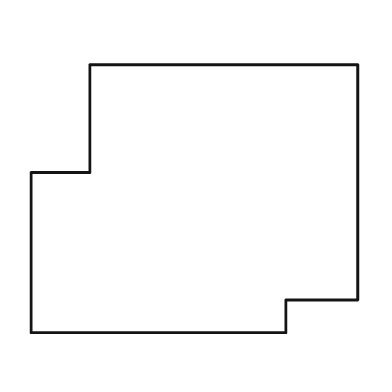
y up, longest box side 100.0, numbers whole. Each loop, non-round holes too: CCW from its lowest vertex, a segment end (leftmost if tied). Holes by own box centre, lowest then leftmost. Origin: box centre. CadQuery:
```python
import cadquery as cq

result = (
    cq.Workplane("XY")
    .moveTo(-50.0, -41.0)
    .lineTo(28.0, -41.0)
    .lineTo(28.0, -31.0)
    .lineTo(50.0, -31.0)
    .lineTo(50.0, 41.0)
    .lineTo(-32.0, 41.0)
    .lineTo(-32.0, 8.0)
    .lineTo(-50.0, 8.0)
    .close()
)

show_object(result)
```